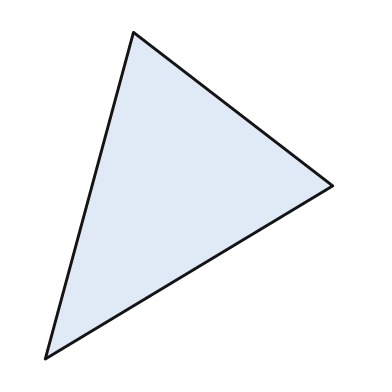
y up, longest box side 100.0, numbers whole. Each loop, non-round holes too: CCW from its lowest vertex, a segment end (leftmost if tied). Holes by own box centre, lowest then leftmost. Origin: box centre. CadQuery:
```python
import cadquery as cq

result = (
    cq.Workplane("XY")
    .moveTo(-44.0, -50.0)
    .lineTo(44.0, 3.0)
    .lineTo(-17.0, 50.0)
    .close()
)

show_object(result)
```